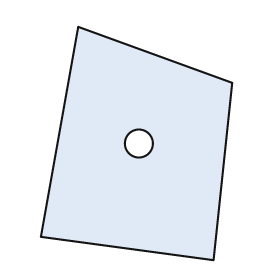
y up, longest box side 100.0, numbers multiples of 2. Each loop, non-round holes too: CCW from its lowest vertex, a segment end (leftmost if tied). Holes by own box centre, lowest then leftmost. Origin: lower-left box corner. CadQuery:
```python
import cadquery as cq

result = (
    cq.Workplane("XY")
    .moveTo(74.0, 0.0)
    .lineTo(82.0, 76.0)
    .lineTo(16.0, 100.0)
    .lineTo(0.0, 10.0)
    .close()
    .moveTo(42.0, 50.0)
    .circle(6.0)
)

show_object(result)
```